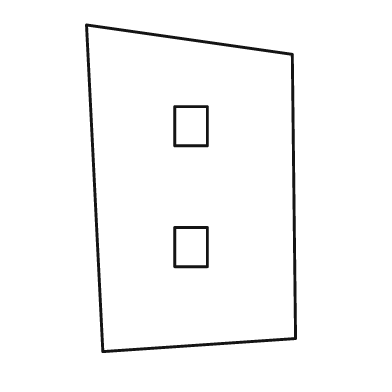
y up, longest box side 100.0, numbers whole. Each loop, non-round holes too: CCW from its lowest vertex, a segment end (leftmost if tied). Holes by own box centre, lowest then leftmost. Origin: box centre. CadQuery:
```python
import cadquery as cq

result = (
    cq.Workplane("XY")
    .moveTo(-27.0, -50.0)
    .lineTo(32.0, -46.0)
    .lineTo(31.0, 41.0)
    .lineTo(-32.0, 50.0)
    .close()
    .moveTo(-5.0, -24.0)
    .lineTo(5.0, -24.0)
    .lineTo(5.0, -12.0)
    .lineTo(-5.0, -12.0)
    .close()
    .moveTo(-5.0, 13.0)
    .lineTo(5.0, 13.0)
    .lineTo(5.0, 25.0)
    .lineTo(-5.0, 25.0)
    .close()
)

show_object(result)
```